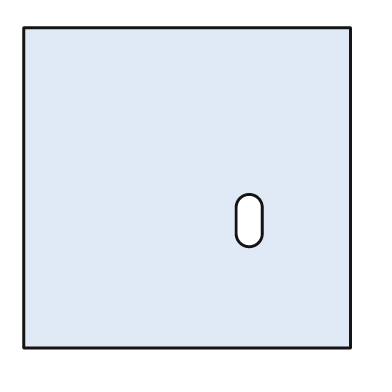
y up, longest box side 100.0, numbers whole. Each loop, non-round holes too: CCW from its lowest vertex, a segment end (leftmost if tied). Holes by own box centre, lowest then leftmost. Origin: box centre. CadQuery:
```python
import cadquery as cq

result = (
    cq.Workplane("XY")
    .moveTo(-50.0, -49.0)
    .lineTo(50.0, -49.0)
    .lineTo(50.0, 49.0)
    .lineTo(-50.0, 49.0)
    .close()
    .moveTo(15.0, -14.0)
    .threePointArc((19.0, -18.0), (23.0, -14.0))
    .lineTo(23.0, -6.0)
    .threePointArc((19.0, -2.0), (15.0, -6.0))
    .close()
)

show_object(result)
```